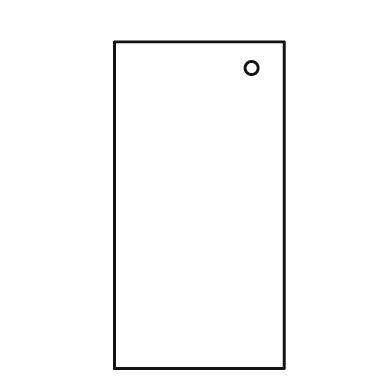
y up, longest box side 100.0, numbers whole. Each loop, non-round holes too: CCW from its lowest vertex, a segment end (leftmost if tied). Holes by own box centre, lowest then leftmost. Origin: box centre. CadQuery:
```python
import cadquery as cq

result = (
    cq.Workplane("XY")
    .moveTo(-26.0, -50.0)
    .lineTo(26.0, -50.0)
    .lineTo(26.0, 50.0)
    .lineTo(-26.0, 50.0)
    .close()
    .moveTo(16.0, 42.0)
    .circle(2.0)
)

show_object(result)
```